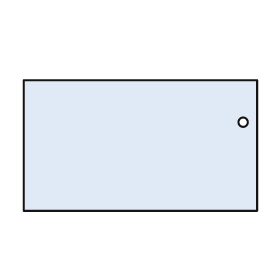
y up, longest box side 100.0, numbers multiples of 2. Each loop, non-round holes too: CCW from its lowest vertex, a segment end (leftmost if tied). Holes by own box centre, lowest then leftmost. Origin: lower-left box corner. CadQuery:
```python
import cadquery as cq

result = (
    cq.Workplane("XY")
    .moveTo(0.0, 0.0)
    .lineTo(100.0, 0.0)
    .lineTo(100.0, 56.0)
    .lineTo(0.0, 56.0)
    .close()
    .moveTo(94.0, 38.0)
    .circle(2.0)
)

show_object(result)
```